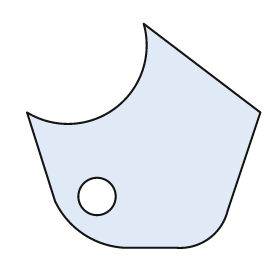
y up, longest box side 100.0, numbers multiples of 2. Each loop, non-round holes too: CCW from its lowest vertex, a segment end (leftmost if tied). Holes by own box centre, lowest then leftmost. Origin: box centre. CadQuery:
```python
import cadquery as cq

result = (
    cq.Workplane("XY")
    .moveTo(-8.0, -48.0)
    .lineTo(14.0, -48.0)
    .threePointArc((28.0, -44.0), (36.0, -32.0))
    .lineTo(50.0, 10.0)
    .lineTo(0.0, 48.0)
    .threePointArc((-12.0, 12.0), (-50.0, 10.0))
    .lineTo(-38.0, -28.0)
    .threePointArc((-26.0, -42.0), (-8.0, -48.0))
    .close()
    .moveTo(-20.0, -26.0)
    .circle(8.0)
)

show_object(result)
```